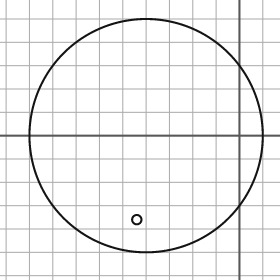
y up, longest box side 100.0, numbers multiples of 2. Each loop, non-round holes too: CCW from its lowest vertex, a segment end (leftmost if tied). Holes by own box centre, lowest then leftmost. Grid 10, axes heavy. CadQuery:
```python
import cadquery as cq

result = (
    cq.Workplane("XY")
    .moveTo(-40.0, 0.0)
    .circle(50.0)
    .moveTo(-44.0, -36.0)
    .circle(2.0)
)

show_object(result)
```